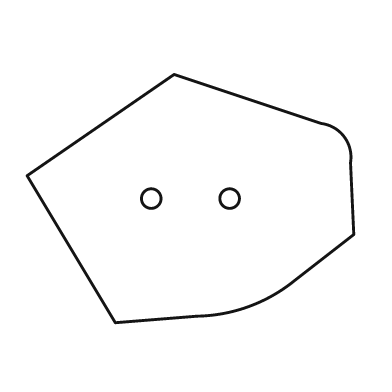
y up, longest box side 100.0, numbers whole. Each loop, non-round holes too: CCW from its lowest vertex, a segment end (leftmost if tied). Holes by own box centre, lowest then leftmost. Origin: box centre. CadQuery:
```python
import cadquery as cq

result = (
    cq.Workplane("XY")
    .moveTo(-23.0, -38.0)
    .lineTo(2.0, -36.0)
    .threePointArc((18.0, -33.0), (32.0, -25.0))
    .lineTo(50.0, -11.0)
    .lineTo(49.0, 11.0)
    .threePointArc((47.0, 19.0), (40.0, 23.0))
    .lineTo(-5.0, 38.0)
    .lineTo(-50.0, 7.0)
    .close()
    .moveTo(-12.0, 0.0)
    .circle(3.0)
    .moveTo(12.0, 0.0)
    .circle(3.0)
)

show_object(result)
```